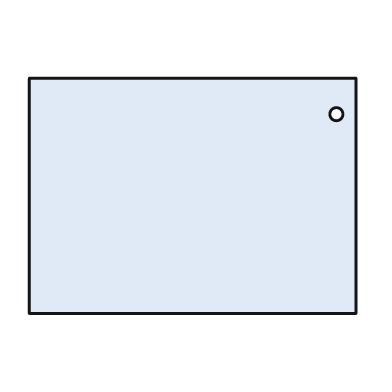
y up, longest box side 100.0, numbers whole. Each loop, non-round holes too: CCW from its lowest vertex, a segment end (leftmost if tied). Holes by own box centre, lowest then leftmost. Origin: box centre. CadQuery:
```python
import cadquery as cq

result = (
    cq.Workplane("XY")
    .moveTo(-50.0, -36.0)
    .lineTo(50.0, -36.0)
    .lineTo(50.0, 36.0)
    .lineTo(-50.0, 36.0)
    .close()
    .moveTo(44.0, 25.0)
    .circle(2.0)
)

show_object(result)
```